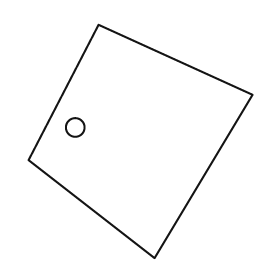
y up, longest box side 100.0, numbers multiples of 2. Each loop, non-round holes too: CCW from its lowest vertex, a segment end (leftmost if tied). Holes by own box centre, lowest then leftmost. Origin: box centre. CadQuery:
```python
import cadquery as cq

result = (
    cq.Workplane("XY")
    .moveTo(6.0, -50.0)
    .lineTo(48.0, 20.0)
    .lineTo(-18.0, 50.0)
    .lineTo(-48.0, -8.0)
    .close()
    .moveTo(-28.0, 6.0)
    .circle(4.0)
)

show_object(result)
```